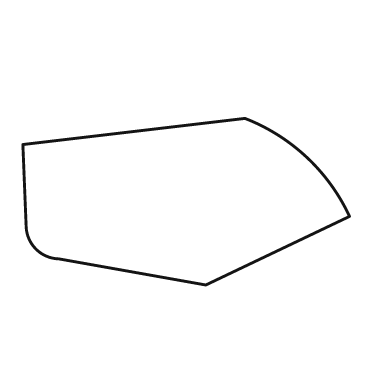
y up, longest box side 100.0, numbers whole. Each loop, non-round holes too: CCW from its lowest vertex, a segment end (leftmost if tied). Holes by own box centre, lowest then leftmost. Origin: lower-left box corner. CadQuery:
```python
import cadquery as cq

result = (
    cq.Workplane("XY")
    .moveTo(56.0, 0.0)
    .lineTo(100.0, 21.0)
    .threePointArc((87.0, 39.0), (68.0, 51.0))
    .lineTo(0.0, 43.0)
    .lineTo(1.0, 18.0)
    .threePointArc((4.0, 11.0), (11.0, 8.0))
    .close()
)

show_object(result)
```